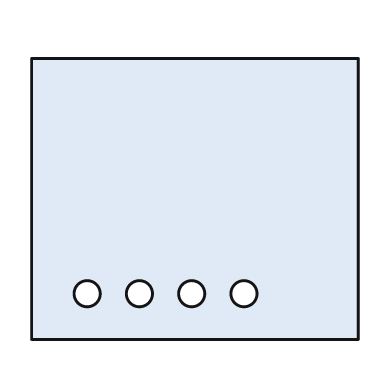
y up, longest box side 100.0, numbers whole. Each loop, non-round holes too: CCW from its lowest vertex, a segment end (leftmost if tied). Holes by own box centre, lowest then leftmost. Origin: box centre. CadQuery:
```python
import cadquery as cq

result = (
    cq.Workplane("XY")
    .moveTo(-50.0, -43.0)
    .lineTo(50.0, -43.0)
    .lineTo(50.0, 43.0)
    .lineTo(-50.0, 43.0)
    .close()
    .moveTo(-33.0, -29.0)
    .circle(4.0)
    .moveTo(-17.0, -29.0)
    .circle(4.0)
    .moveTo(-1.0, -29.0)
    .circle(4.0)
    .moveTo(15.0, -29.0)
    .circle(4.0)
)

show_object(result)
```